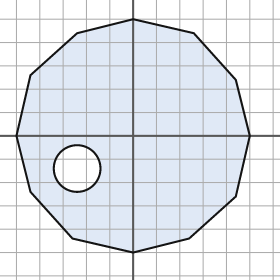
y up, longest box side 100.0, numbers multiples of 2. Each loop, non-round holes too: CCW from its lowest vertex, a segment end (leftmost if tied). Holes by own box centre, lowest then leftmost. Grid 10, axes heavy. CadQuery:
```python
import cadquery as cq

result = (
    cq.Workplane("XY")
    .moveTo(0.0, -50.0)
    .lineTo(24.0, -44.0)
    .lineTo(44.0, -26.0)
    .lineTo(50.0, 0.0)
    .lineTo(44.0, 24.0)
    .lineTo(26.0, 44.0)
    .lineTo(0.0, 50.0)
    .lineTo(-24.0, 44.0)
    .lineTo(-44.0, 26.0)
    .lineTo(-50.0, 0.0)
    .lineTo(-44.0, -24.0)
    .lineTo(-26.0, -44.0)
    .close()
    .moveTo(-24.0, -14.0)
    .circle(10.0)
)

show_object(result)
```